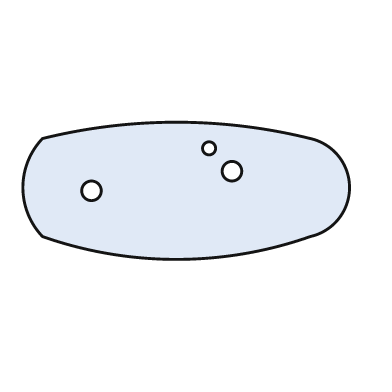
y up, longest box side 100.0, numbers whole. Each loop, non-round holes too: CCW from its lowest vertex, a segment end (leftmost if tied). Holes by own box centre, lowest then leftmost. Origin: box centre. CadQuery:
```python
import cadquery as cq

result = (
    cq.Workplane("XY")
    .moveTo(-44.0, -14.0)
    .threePointArc((-3.0, -21.0), (38.0, -14.0))
    .threePointArc((50.0, 1.0), (38.0, 16.0))
    .threePointArc((-3.0, 21.0), (-44.0, 16.0))
    .threePointArc((-50.0, 1.0), (-44.0, -14.0))
    .close()
    .moveTo(-29.0, 0.0)
    .circle(3.0)
    .moveTo(14.0, 6.0)
    .circle(3.0)
    .moveTo(7.0, 13.0)
    .circle(2.0)
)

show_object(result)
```